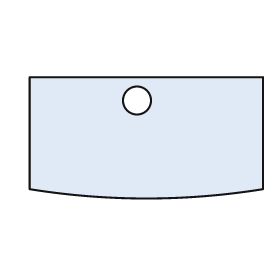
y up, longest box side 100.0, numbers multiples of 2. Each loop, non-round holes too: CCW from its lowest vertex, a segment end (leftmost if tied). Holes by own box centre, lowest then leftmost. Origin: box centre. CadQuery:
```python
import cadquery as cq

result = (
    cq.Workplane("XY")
    .moveTo(-50.0, -22.0)
    .threePointArc((0.0, -26.0), (50.0, -22.0))
    .lineTo(50.0, 26.0)
    .lineTo(-50.0, 26.0)
    .close()
    .moveTo(-4.0, 16.0)
    .circle(6.0)
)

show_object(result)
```